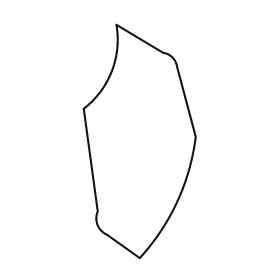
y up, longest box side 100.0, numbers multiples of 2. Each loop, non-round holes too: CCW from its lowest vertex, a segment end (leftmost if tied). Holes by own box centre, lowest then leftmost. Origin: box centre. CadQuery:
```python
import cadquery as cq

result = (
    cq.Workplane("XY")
    .moveTo(0.0, -50.0)
    .threePointArc((16.0, -26.0), (24.0, 2.0))
    .lineTo(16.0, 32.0)
    .threePointArc((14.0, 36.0), (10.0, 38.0))
    .lineTo(-10.0, 50.0)
    .threePointArc((-12.0, 30.0), (-24.0, 14.0))
    .lineTo(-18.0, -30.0)
    .threePointArc((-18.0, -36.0), (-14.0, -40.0))
    .close()
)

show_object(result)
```